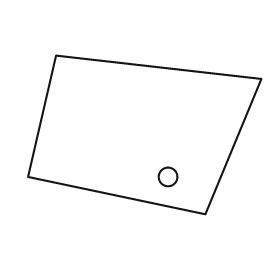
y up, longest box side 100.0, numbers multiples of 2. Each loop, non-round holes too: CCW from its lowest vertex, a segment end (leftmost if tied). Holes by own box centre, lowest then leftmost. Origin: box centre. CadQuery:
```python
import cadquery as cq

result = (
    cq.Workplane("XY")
    .moveTo(26.0, -34.0)
    .lineTo(50.0, 24.0)
    .lineTo(-38.0, 34.0)
    .lineTo(-50.0, -18.0)
    .close()
    .moveTo(10.0, -18.0)
    .circle(4.0)
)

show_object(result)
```